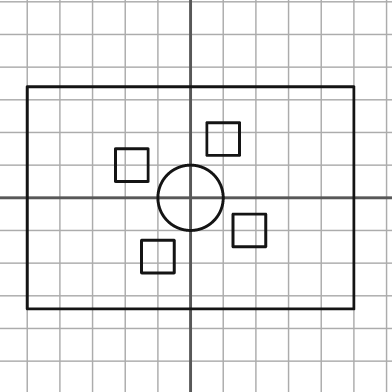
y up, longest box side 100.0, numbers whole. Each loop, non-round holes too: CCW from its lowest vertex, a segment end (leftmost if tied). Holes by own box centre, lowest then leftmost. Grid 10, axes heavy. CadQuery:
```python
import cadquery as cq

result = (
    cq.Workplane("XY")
    .moveTo(-50.0, -34.0)
    .lineTo(50.0, -34.0)
    .lineTo(50.0, 34.0)
    .lineTo(-50.0, 34.0)
    .close()
    .moveTo(-15.0, -23.0)
    .lineTo(-5.0, -23.0)
    .lineTo(-5.0, -13.0)
    .lineTo(-15.0, -13.0)
    .close()
    .moveTo(13.0, -15.0)
    .lineTo(23.0, -15.0)
    .lineTo(23.0, -5.0)
    .lineTo(13.0, -5.0)
    .close()
    .moveTo(0.0, 0.0)
    .circle(10.0)
    .moveTo(-23.0, 5.0)
    .lineTo(-13.0, 5.0)
    .lineTo(-13.0, 15.0)
    .lineTo(-23.0, 15.0)
    .close()
    .moveTo(5.0, 13.0)
    .lineTo(15.0, 13.0)
    .lineTo(15.0, 23.0)
    .lineTo(5.0, 23.0)
    .close()
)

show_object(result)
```